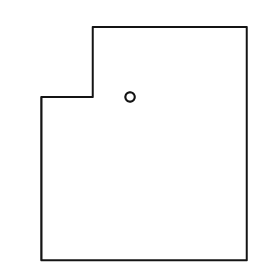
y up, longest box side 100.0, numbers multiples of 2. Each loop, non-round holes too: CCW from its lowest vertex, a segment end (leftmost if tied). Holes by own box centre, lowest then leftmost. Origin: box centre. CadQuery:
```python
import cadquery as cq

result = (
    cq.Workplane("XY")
    .moveTo(-44.0, -50.0)
    .lineTo(44.0, -50.0)
    .lineTo(44.0, 50.0)
    .lineTo(-22.0, 50.0)
    .lineTo(-22.0, 20.0)
    .lineTo(-44.0, 20.0)
    .close()
    .moveTo(-6.0, 20.0)
    .circle(2.0)
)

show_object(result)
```